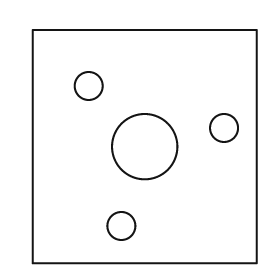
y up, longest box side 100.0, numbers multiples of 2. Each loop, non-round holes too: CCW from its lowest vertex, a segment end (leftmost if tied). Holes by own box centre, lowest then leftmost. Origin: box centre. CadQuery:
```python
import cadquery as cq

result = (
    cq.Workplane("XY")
    .moveTo(-48.0, -50.0)
    .lineTo(48.0, -50.0)
    .lineTo(48.0, 50.0)
    .lineTo(-48.0, 50.0)
    .close()
    .moveTo(-10.0, -34.0)
    .circle(6.0)
    .moveTo(0.0, 0.0)
    .circle(14.0)
    .moveTo(34.0, 8.0)
    .circle(6.0)
    .moveTo(-24.0, 26.0)
    .circle(6.0)
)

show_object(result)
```